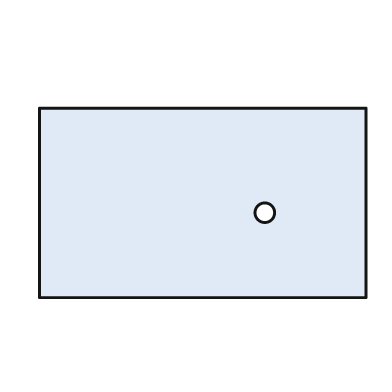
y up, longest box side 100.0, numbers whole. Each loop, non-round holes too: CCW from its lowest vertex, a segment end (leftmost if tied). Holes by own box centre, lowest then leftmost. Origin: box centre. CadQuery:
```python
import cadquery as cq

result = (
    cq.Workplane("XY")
    .moveTo(-50.0, -29.0)
    .lineTo(50.0, -29.0)
    .lineTo(50.0, 29.0)
    .lineTo(-50.0, 29.0)
    .close()
    .moveTo(19.0, -3.0)
    .circle(3.0)
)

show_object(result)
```